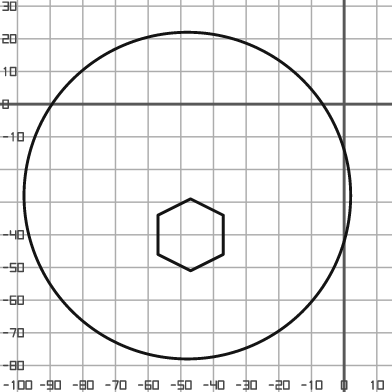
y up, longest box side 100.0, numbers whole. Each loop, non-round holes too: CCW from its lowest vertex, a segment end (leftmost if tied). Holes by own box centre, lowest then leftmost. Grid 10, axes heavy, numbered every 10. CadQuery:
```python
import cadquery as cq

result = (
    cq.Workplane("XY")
    .moveTo(-48.0, -28.0)
    .circle(50.0)
    .moveTo(-47.0, -51.0)
    .lineTo(-37.0, -46.0)
    .lineTo(-37.0, -34.0)
    .lineTo(-47.0, -29.0)
    .lineTo(-57.0, -34.0)
    .lineTo(-57.0, -46.0)
    .close()
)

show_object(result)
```